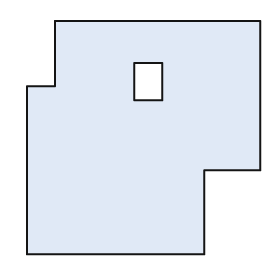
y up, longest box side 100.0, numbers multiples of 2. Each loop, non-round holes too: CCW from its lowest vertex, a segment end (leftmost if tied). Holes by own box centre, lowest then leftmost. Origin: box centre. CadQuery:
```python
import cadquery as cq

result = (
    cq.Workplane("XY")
    .moveTo(-50.0, -50.0)
    .lineTo(26.0, -50.0)
    .lineTo(26.0, -14.0)
    .lineTo(50.0, -14.0)
    .lineTo(50.0, 50.0)
    .lineTo(-38.0, 50.0)
    .lineTo(-38.0, 22.0)
    .lineTo(-50.0, 22.0)
    .close()
    .moveTo(-4.0, 16.0)
    .lineTo(8.0, 16.0)
    .lineTo(8.0, 32.0)
    .lineTo(-4.0, 32.0)
    .close()
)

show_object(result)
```